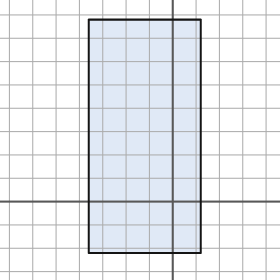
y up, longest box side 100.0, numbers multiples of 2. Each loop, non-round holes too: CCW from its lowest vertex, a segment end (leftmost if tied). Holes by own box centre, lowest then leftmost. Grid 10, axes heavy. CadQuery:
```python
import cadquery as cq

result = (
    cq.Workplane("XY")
    .moveTo(-36.0, -22.0)
    .lineTo(12.0, -22.0)
    .lineTo(12.0, 78.0)
    .lineTo(-36.0, 78.0)
    .close()
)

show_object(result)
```